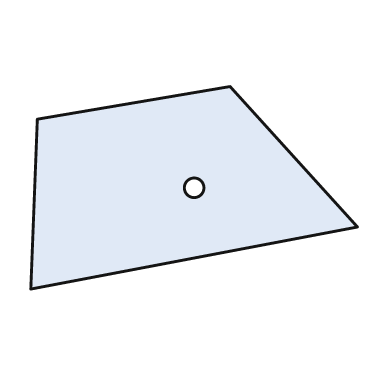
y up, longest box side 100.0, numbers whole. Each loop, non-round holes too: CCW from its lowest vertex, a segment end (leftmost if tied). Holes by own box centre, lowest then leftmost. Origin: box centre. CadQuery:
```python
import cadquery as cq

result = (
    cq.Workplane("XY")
    .moveTo(-50.0, -31.0)
    .lineTo(50.0, -12.0)
    .lineTo(11.0, 31.0)
    .lineTo(-48.0, 21.0)
    .close()
    .moveTo(0.0, 0.0)
    .circle(3.0)
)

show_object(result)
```